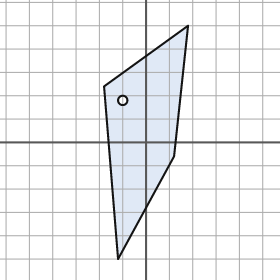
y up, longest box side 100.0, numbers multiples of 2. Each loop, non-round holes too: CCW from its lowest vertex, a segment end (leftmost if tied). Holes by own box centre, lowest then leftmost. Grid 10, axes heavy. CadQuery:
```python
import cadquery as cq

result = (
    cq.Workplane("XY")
    .moveTo(-12.0, -50.0)
    .lineTo(12.0, -6.0)
    .lineTo(18.0, 50.0)
    .lineTo(-18.0, 24.0)
    .close()
    .moveTo(-10.0, 18.0)
    .circle(2.0)
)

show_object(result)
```